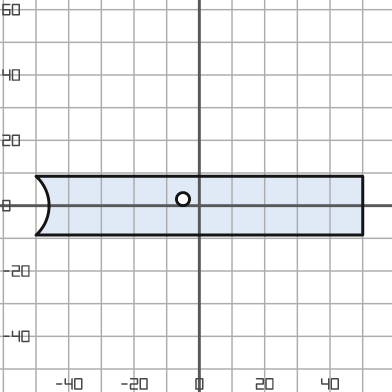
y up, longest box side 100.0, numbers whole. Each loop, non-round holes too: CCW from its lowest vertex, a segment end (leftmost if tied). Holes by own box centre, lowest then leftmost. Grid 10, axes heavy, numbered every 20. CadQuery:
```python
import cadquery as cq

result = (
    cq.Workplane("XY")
    .moveTo(-50.0, -9.0)
    .lineTo(50.0, -9.0)
    .lineTo(50.0, 9.0)
    .lineTo(-50.0, 9.0)
    .threePointArc((-46.0, 0.0), (-50.0, -9.0))
    .close()
    .moveTo(-5.0, 2.0)
    .circle(2.0)
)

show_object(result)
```